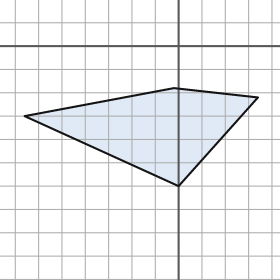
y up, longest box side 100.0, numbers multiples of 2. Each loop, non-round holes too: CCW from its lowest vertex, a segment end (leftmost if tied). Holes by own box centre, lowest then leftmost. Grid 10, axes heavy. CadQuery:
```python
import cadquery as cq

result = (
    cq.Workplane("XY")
    .moveTo(0.0, -60.0)
    .lineTo(34.0, -22.0)
    .lineTo(-2.0, -18.0)
    .lineTo(-66.0, -30.0)
    .close()
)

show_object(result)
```